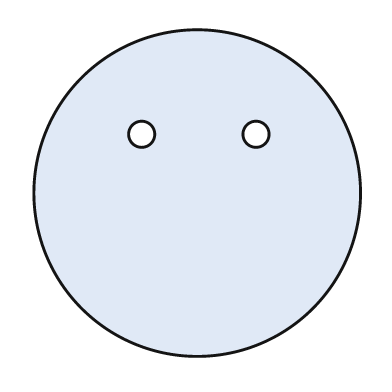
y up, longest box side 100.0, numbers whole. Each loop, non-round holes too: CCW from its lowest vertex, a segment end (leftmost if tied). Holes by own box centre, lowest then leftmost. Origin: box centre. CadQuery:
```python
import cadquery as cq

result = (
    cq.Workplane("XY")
    .moveTo(0.0, 0.0)
    .circle(50.0)
    .moveTo(-17.0, 18.0)
    .circle(4.0)
    .moveTo(18.0, 18.0)
    .circle(4.0)
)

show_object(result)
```